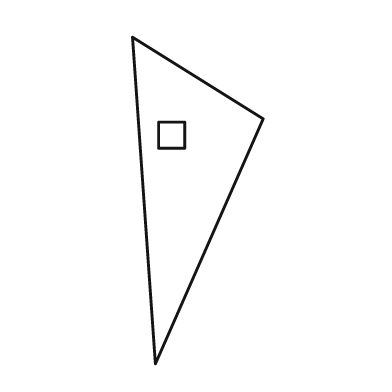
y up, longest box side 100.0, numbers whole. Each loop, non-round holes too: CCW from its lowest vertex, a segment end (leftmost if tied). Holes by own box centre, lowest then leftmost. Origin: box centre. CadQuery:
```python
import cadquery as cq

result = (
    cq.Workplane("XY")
    .moveTo(-13.0, -50.0)
    .lineTo(20.0, 25.0)
    .lineTo(-20.0, 50.0)
    .close()
    .moveTo(-12.0, 16.0)
    .lineTo(-4.0, 16.0)
    .lineTo(-4.0, 24.0)
    .lineTo(-12.0, 24.0)
    .close()
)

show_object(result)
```